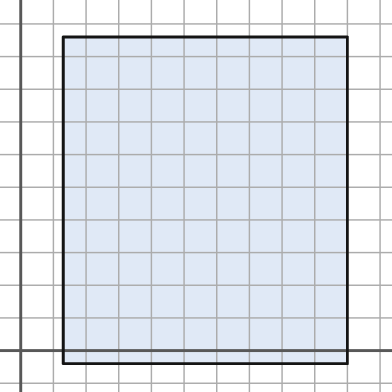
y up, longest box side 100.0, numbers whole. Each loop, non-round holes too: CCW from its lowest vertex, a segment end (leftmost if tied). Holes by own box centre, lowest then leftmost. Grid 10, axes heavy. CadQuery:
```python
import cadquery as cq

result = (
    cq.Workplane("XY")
    .moveTo(13.0, -4.0)
    .lineTo(100.0, -4.0)
    .lineTo(100.0, 96.0)
    .lineTo(13.0, 96.0)
    .close()
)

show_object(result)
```